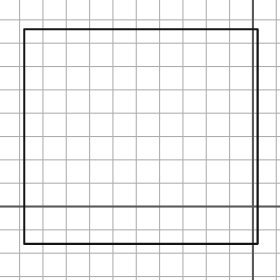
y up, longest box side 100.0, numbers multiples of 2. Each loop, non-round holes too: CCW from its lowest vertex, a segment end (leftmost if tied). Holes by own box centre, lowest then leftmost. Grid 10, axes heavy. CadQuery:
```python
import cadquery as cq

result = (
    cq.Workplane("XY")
    .moveTo(-98.0, -16.0)
    .lineTo(2.0, -16.0)
    .lineTo(2.0, 76.0)
    .lineTo(-98.0, 76.0)
    .close()
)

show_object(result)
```